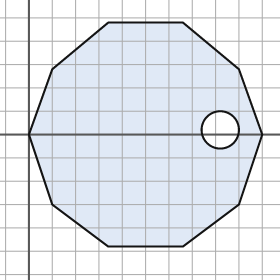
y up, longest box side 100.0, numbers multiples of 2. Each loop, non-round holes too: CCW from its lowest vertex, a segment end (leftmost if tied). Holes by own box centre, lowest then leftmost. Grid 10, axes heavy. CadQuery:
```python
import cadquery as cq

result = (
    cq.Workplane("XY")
    .moveTo(34.0, -48.0)
    .lineTo(66.0, -48.0)
    .lineTo(90.0, -30.0)
    .lineTo(100.0, 0.0)
    .lineTo(90.0, 28.0)
    .lineTo(66.0, 48.0)
    .lineTo(34.0, 48.0)
    .lineTo(10.0, 28.0)
    .lineTo(0.0, 0.0)
    .lineTo(10.0, -30.0)
    .close()
    .moveTo(82.0, 2.0)
    .circle(8.0)
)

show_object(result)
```